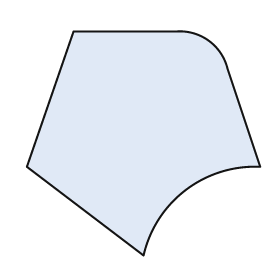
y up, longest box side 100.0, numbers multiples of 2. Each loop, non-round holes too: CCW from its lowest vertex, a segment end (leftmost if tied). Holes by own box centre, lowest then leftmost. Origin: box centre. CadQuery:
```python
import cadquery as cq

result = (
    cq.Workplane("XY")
    .moveTo(0.0, -48.0)
    .threePointArc((18.0, -20.0), (50.0, -10.0))
    .lineTo(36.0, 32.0)
    .threePointArc((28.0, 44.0), (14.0, 48.0))
    .lineTo(-30.0, 48.0)
    .lineTo(-50.0, -10.0)
    .close()
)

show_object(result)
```